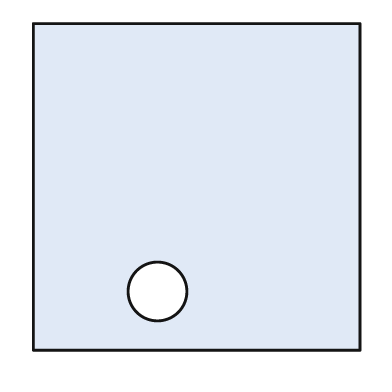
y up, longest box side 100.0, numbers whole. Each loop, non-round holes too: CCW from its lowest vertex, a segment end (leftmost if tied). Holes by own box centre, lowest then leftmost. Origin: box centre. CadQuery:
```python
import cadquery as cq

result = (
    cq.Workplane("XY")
    .moveTo(-50.0, -50.0)
    .lineTo(50.0, -50.0)
    .lineTo(50.0, 50.0)
    .lineTo(-50.0, 50.0)
    .close()
    .moveTo(-12.0, -32.0)
    .circle(9.0)
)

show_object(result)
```